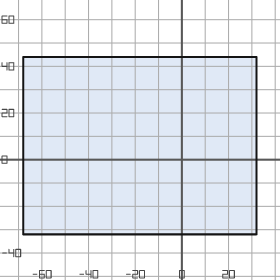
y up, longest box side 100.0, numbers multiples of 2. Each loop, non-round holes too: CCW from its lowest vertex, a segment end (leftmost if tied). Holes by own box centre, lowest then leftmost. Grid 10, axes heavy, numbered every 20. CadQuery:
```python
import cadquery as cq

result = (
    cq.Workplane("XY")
    .moveTo(-68.0, -32.0)
    .lineTo(32.0, -32.0)
    .lineTo(32.0, 44.0)
    .lineTo(-68.0, 44.0)
    .close()
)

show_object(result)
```